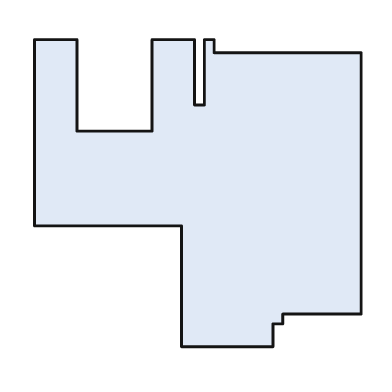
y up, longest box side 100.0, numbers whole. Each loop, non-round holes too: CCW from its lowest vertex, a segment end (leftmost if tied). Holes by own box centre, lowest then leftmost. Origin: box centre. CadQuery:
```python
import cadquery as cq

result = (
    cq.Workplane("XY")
    .moveTo(-5.0, -47.0)
    .lineTo(23.0, -47.0)
    .lineTo(23.0, -40.0)
    .lineTo(26.0, -40.0)
    .lineTo(26.0, -37.0)
    .lineTo(50.0, -37.0)
    .lineTo(50.0, 43.0)
    .lineTo(5.0, 43.0)
    .lineTo(5.0, 47.0)
    .lineTo(2.0, 47.0)
    .lineTo(2.0, 27.0)
    .lineTo(-1.0, 27.0)
    .lineTo(-1.0, 47.0)
    .lineTo(-14.0, 47.0)
    .lineTo(-14.0, 19.0)
    .lineTo(-37.0, 19.0)
    .lineTo(-37.0, 47.0)
    .lineTo(-50.0, 47.0)
    .lineTo(-50.0, -10.0)
    .lineTo(-5.0, -10.0)
    .close()
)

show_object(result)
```